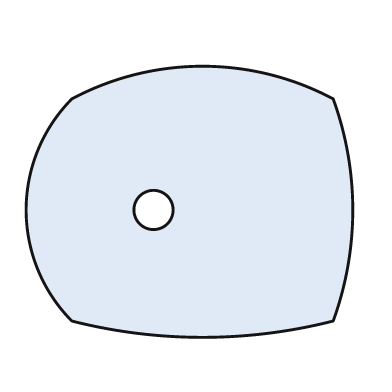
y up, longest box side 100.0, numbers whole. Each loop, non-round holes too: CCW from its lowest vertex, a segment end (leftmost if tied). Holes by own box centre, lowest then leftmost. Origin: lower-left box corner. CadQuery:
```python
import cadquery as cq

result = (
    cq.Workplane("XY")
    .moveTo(14.0, 5.0)
    .threePointArc((54.0, 0.0), (94.0, 5.0))
    .threePointArc((100.0, 39.0), (94.0, 73.0))
    .threePointArc((54.0, 83.0), (14.0, 73.0))
    .threePointArc((0.0, 39.0), (14.0, 5.0))
    .close()
    .moveTo(39.0, 39.0)
    .circle(6.0)
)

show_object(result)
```